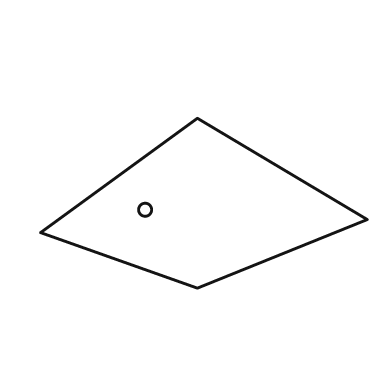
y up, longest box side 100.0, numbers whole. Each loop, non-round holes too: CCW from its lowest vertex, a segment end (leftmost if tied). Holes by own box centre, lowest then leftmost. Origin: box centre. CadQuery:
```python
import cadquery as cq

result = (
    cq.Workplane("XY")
    .moveTo(-2.0, -26.0)
    .lineTo(50.0, -5.0)
    .lineTo(-2.0, 26.0)
    .lineTo(-50.0, -9.0)
    .close()
    .moveTo(-18.0, -2.0)
    .circle(2.0)
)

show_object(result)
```